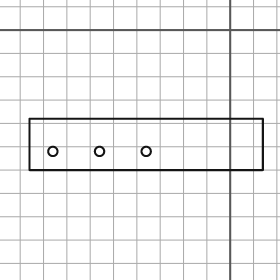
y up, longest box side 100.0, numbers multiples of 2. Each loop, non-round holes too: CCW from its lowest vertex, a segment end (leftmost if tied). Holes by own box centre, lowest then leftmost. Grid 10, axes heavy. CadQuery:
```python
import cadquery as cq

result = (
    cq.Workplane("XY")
    .moveTo(-86.0, -60.0)
    .lineTo(14.0, -60.0)
    .lineTo(14.0, -38.0)
    .lineTo(-86.0, -38.0)
    .close()
    .moveTo(-76.0, -52.0)
    .circle(2.0)
    .moveTo(-56.0, -52.0)
    .circle(2.0)
    .moveTo(-36.0, -52.0)
    .circle(2.0)
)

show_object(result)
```